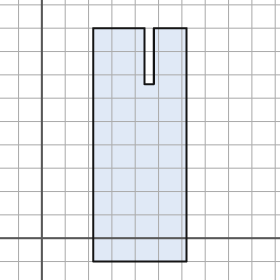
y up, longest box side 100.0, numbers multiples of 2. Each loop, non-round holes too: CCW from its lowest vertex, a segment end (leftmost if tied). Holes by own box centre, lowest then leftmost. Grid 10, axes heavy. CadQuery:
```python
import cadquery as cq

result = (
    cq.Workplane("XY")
    .moveTo(22.0, -10.0)
    .lineTo(62.0, -10.0)
    .lineTo(62.0, 90.0)
    .lineTo(48.0, 90.0)
    .lineTo(48.0, 66.0)
    .lineTo(44.0, 66.0)
    .lineTo(44.0, 90.0)
    .lineTo(22.0, 90.0)
    .close()
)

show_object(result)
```